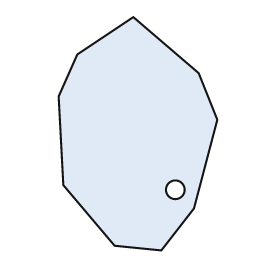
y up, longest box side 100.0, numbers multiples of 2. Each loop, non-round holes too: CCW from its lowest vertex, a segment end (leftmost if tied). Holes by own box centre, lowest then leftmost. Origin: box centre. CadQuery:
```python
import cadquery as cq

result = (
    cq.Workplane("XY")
    .moveTo(10.0, -50.0)
    .lineTo(24.0, -32.0)
    .lineTo(34.0, 6.0)
    .lineTo(26.0, 26.0)
    .lineTo(-2.0, 50.0)
    .lineTo(-26.0, 34.0)
    .lineTo(-34.0, 16.0)
    .lineTo(-32.0, -22.0)
    .lineTo(-10.0, -48.0)
    .close()
    .moveTo(16.0, -24.0)
    .circle(4.0)
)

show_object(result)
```